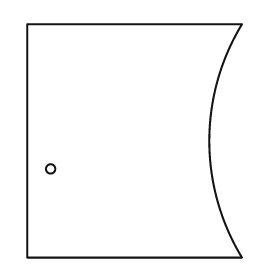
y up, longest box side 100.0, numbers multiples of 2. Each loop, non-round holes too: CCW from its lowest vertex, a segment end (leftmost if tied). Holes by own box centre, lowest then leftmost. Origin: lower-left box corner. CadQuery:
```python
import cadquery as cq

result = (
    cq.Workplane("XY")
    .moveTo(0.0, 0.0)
    .lineTo(92.0, 0.0)
    .threePointArc((78.0, 50.0), (92.0, 100.0))
    .lineTo(0.0, 100.0)
    .close()
    .moveTo(10.0, 38.0)
    .circle(2.0)
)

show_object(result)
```